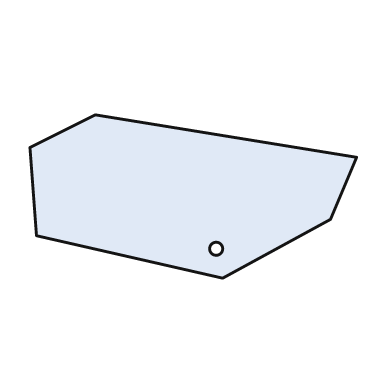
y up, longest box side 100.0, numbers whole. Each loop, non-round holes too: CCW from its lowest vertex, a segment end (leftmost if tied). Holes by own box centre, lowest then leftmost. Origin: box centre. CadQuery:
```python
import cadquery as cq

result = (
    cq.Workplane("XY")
    .moveTo(9.0, -25.0)
    .lineTo(42.0, -7.0)
    .lineTo(50.0, 12.0)
    .lineTo(-30.0, 25.0)
    .lineTo(-50.0, 15.0)
    .lineTo(-48.0, -12.0)
    .close()
    .moveTo(7.0, -16.0)
    .circle(2.0)
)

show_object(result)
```